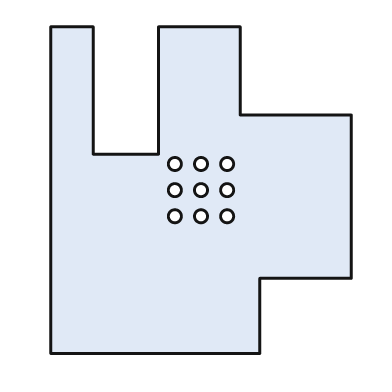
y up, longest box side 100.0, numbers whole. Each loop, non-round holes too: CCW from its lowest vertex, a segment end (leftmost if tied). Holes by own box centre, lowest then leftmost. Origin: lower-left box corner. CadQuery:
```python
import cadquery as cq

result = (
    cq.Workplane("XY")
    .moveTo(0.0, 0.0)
    .lineTo(64.0, 0.0)
    .lineTo(64.0, 23.0)
    .lineTo(92.0, 23.0)
    .lineTo(92.0, 73.0)
    .lineTo(58.0, 73.0)
    .lineTo(58.0, 100.0)
    .lineTo(33.0, 100.0)
    .lineTo(33.0, 61.0)
    .lineTo(13.0, 61.0)
    .lineTo(13.0, 100.0)
    .lineTo(0.0, 100.0)
    .close()
    .moveTo(38.0, 42.0)
    .circle(2.0)
    .moveTo(46.0, 42.0)
    .circle(2.0)
    .moveTo(54.0, 42.0)
    .circle(2.0)
    .moveTo(38.0, 50.0)
    .circle(2.0)
    .moveTo(46.0, 50.0)
    .circle(2.0)
    .moveTo(54.0, 50.0)
    .circle(2.0)
    .moveTo(38.0, 58.0)
    .circle(2.0)
    .moveTo(46.0, 58.0)
    .circle(2.0)
    .moveTo(54.0, 58.0)
    .circle(2.0)
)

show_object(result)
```